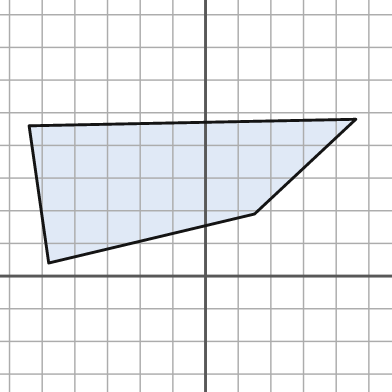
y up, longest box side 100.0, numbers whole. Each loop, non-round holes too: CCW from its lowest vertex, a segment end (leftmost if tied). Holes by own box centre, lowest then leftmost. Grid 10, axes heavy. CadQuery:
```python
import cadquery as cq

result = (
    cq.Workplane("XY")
    .moveTo(-48.0, 4.0)
    .lineTo(15.0, 19.0)
    .lineTo(46.0, 48.0)
    .lineTo(-54.0, 46.0)
    .close()
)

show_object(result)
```